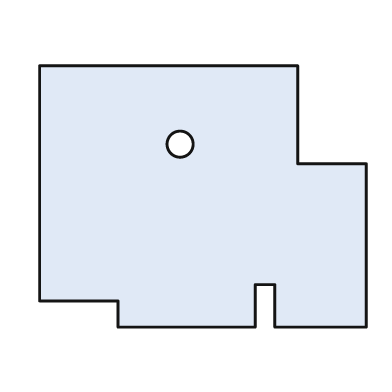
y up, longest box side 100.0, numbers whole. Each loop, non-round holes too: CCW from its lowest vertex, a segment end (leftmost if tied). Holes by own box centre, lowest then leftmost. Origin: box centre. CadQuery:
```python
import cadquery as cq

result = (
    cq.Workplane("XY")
    .moveTo(-26.0, -40.0)
    .lineTo(16.0, -40.0)
    .lineTo(16.0, -27.0)
    .lineTo(22.0, -27.0)
    .lineTo(22.0, -40.0)
    .lineTo(50.0, -40.0)
    .lineTo(50.0, 10.0)
    .lineTo(29.0, 10.0)
    .lineTo(29.0, 40.0)
    .lineTo(-50.0, 40.0)
    .lineTo(-50.0, -32.0)
    .lineTo(-26.0, -32.0)
    .close()
    .moveTo(-7.0, 16.0)
    .circle(4.0)
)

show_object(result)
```